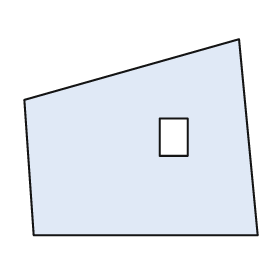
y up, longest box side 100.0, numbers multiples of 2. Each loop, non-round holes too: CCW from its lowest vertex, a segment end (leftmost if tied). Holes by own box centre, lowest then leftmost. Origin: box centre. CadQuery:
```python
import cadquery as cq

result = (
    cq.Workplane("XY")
    .moveTo(-46.0, -42.0)
    .lineTo(50.0, -42.0)
    .lineTo(42.0, 42.0)
    .lineTo(-50.0, 16.0)
    .close()
    .moveTo(8.0, -8.0)
    .lineTo(20.0, -8.0)
    .lineTo(20.0, 8.0)
    .lineTo(8.0, 8.0)
    .close()
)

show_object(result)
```